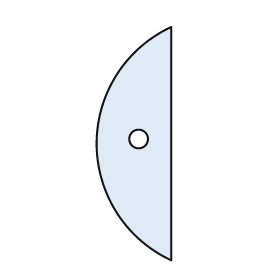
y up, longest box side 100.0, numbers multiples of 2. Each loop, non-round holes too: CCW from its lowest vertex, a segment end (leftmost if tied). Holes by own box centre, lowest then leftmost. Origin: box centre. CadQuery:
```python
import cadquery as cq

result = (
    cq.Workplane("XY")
    .moveTo(16.0, -50.0)
    .lineTo(16.0, 50.0)
    .threePointArc((-16.0, 0.0), (16.0, -50.0))
    .close()
    .moveTo(2.0, 2.0)
    .circle(4.0)
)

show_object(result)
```